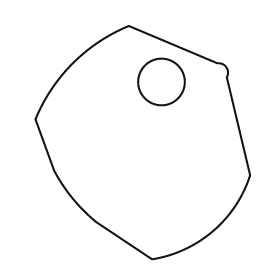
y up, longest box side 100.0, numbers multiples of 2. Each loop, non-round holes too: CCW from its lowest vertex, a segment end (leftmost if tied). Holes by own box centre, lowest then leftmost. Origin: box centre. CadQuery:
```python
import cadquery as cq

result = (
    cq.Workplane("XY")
    .moveTo(4.0, -50.0)
    .threePointArc((30.0, -38.0), (46.0, -14.0))
    .lineTo(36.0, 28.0)
    .threePointArc((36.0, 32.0), (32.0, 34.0))
    .lineTo(-6.0, 50.0)
    .threePointArc((-30.0, 34.0), (-46.0, 10.0))
    .lineTo(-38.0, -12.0)
    .threePointArc((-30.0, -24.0), (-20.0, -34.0))
    .close()
    .moveTo(8.0, 26.0)
    .circle(10.0)
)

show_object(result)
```